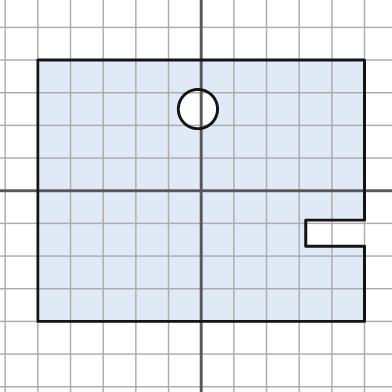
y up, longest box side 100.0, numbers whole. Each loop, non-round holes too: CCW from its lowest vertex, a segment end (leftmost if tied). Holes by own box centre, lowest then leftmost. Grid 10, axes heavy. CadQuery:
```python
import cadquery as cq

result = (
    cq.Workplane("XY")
    .moveTo(-50.0, -40.0)
    .lineTo(50.0, -40.0)
    .lineTo(50.0, -17.0)
    .lineTo(32.0, -17.0)
    .lineTo(32.0, -9.0)
    .lineTo(50.0, -9.0)
    .lineTo(50.0, 40.0)
    .lineTo(-50.0, 40.0)
    .close()
    .moveTo(-1.0, 25.0)
    .circle(6.0)
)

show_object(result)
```